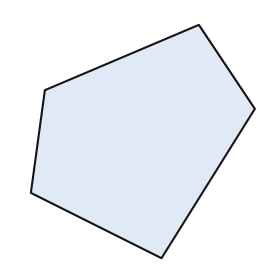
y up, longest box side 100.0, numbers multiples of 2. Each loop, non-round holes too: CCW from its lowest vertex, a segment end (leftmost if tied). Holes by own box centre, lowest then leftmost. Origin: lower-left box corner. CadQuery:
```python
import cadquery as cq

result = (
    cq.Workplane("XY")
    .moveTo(56.0, 0.0)
    .lineTo(96.0, 64.0)
    .lineTo(72.0, 100.0)
    .lineTo(6.0, 72.0)
    .lineTo(0.0, 28.0)
    .close()
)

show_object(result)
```